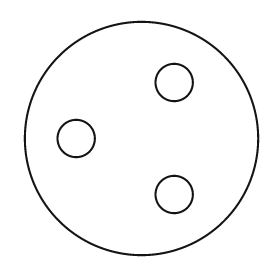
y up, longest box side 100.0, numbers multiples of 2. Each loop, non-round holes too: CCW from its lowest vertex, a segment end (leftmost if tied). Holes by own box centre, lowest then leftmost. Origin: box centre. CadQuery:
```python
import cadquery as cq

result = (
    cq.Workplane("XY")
    .moveTo(0.0, 0.0)
    .circle(50.0)
    .moveTo(14.0, -24.0)
    .circle(8.0)
    .moveTo(-28.0, 0.0)
    .circle(8.0)
    .moveTo(14.0, 24.0)
    .circle(8.0)
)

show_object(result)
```